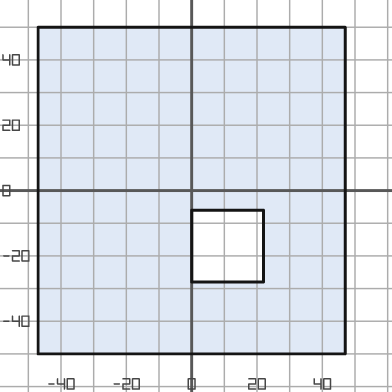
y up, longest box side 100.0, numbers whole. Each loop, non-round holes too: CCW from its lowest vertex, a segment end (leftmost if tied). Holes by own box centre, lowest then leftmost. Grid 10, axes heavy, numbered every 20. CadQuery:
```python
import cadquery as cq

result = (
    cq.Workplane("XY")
    .moveTo(-47.0, -50.0)
    .lineTo(47.0, -50.0)
    .lineTo(47.0, 50.0)
    .lineTo(-47.0, 50.0)
    .close()
    .moveTo(0.0, -28.0)
    .lineTo(22.0, -28.0)
    .lineTo(22.0, -6.0)
    .lineTo(0.0, -6.0)
    .close()
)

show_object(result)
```